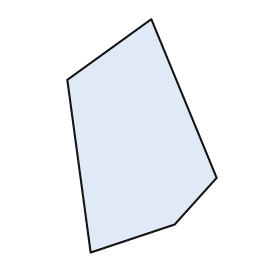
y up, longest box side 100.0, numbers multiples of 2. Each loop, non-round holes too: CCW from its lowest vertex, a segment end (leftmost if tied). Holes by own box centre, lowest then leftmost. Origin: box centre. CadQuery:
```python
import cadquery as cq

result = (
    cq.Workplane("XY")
    .moveTo(-22.0, -50.0)
    .lineTo(14.0, -38.0)
    .lineTo(32.0, -18.0)
    .lineTo(4.0, 50.0)
    .lineTo(-32.0, 24.0)
    .close()
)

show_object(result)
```